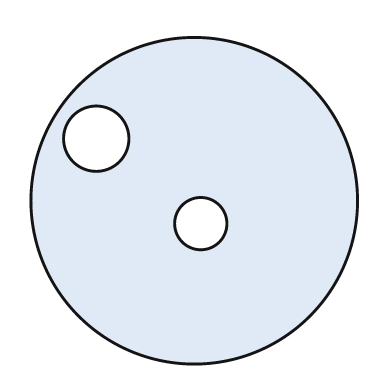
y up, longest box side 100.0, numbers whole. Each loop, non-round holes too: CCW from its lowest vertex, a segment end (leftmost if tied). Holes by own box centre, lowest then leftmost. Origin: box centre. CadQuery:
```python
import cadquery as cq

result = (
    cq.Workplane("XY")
    .moveTo(0.0, 0.0)
    .circle(50.0)
    .moveTo(2.0, -7.0)
    .circle(8.0)
    .moveTo(-30.0, 19.0)
    .circle(10.0)
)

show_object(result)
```